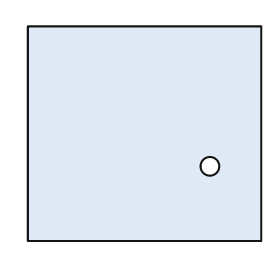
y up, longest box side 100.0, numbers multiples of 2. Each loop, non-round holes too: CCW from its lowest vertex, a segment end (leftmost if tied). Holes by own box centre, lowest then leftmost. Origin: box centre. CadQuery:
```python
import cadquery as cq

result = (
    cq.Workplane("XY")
    .moveTo(-50.0, -46.0)
    .lineTo(50.0, -46.0)
    .lineTo(50.0, 46.0)
    .lineTo(-50.0, 46.0)
    .close()
    .moveTo(28.0, -14.0)
    .circle(4.0)
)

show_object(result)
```